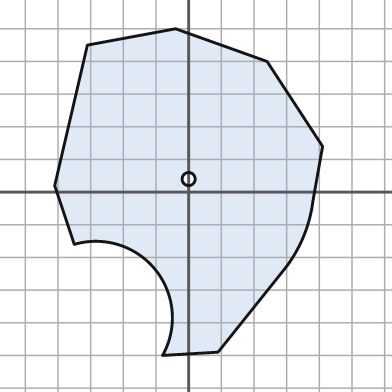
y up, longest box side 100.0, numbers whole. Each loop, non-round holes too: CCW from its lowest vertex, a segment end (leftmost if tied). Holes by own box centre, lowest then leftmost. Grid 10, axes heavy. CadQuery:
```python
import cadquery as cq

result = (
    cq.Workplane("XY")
    .moveTo(-8.0, -50.0)
    .lineTo(9.0, -49.0)
    .lineTo(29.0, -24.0)
    .threePointArc((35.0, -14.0), (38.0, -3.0))
    .lineTo(41.0, 14.0)
    .lineTo(24.0, 40.0)
    .lineTo(-4.0, 50.0)
    .lineTo(-31.0, 45.0)
    .lineTo(-41.0, 2.0)
    .lineTo(-35.0, -16.0)
    .threePointArc((-10.0, -24.0), (-8.0, -50.0))
    .close()
    .moveTo(0.0, 4.0)
    .circle(2.0)
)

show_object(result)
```